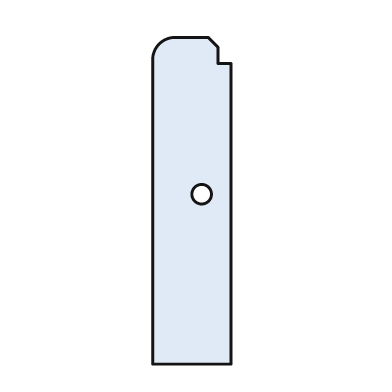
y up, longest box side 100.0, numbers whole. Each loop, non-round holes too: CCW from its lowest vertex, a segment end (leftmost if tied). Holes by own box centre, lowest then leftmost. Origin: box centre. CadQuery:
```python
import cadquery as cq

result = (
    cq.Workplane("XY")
    .moveTo(-12.0, -50.0)
    .lineTo(12.0, -50.0)
    .lineTo(12.0, 42.0)
    .lineTo(8.0, 42.0)
    .lineTo(8.0, 47.0)
    .lineTo(5.0, 50.0)
    .lineTo(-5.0, 50.0)
    .threePointArc((-10.0, 48.0), (-12.0, 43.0))
    .close()
    .moveTo(3.0, 2.0)
    .circle(3.0)
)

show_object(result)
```